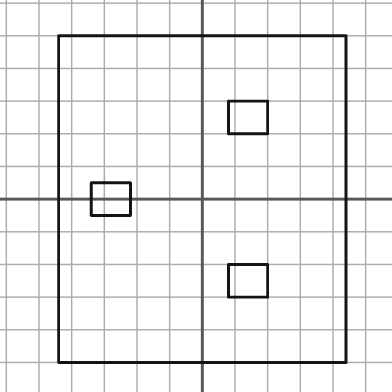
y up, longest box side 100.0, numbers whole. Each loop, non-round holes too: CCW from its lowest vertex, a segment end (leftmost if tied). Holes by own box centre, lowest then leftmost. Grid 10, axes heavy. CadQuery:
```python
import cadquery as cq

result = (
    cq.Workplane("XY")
    .moveTo(-44.0, -50.0)
    .lineTo(44.0, -50.0)
    .lineTo(44.0, 50.0)
    .lineTo(-44.0, 50.0)
    .close()
    .moveTo(8.0, -30.0)
    .lineTo(20.0, -30.0)
    .lineTo(20.0, -20.0)
    .lineTo(8.0, -20.0)
    .close()
    .moveTo(-34.0, -5.0)
    .lineTo(-22.0, -5.0)
    .lineTo(-22.0, 5.0)
    .lineTo(-34.0, 5.0)
    .close()
    .moveTo(8.0, 20.0)
    .lineTo(20.0, 20.0)
    .lineTo(20.0, 30.0)
    .lineTo(8.0, 30.0)
    .close()
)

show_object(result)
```